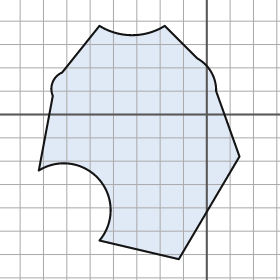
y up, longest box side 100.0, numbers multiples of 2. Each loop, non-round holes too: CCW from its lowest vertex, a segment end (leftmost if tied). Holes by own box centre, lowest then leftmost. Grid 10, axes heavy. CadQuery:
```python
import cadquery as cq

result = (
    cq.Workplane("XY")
    .moveTo(-12.0, -62.0)
    .lineTo(14.0, -18.0)
    .lineTo(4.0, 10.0)
    .threePointArc((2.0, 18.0), (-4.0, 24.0))
    .lineTo(-18.0, 38.0)
    .threePointArc((-32.0, 34.0), (-46.0, 38.0))
    .lineTo(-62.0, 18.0)
    .threePointArc((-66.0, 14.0), (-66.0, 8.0))
    .lineTo(-72.0, -24.0)
    .threePointArc((-46.0, -28.0), (-46.0, -54.0))
    .close()
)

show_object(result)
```